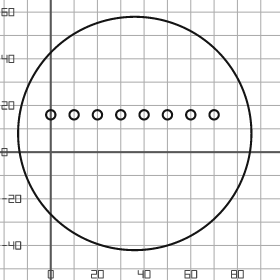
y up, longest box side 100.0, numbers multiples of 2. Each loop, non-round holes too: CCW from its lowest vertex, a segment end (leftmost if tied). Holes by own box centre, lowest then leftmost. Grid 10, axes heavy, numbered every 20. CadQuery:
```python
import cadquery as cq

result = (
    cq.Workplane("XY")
    .moveTo(36.0, 8.0)
    .circle(50.0)
    .moveTo(0.0, 16.0)
    .circle(2.0)
    .moveTo(10.0, 16.0)
    .circle(2.0)
    .moveTo(20.0, 16.0)
    .circle(2.0)
    .moveTo(30.0, 16.0)
    .circle(2.0)
    .moveTo(40.0, 16.0)
    .circle(2.0)
    .moveTo(50.0, 16.0)
    .circle(2.0)
    .moveTo(60.0, 16.0)
    .circle(2.0)
    .moveTo(70.0, 16.0)
    .circle(2.0)
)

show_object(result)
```